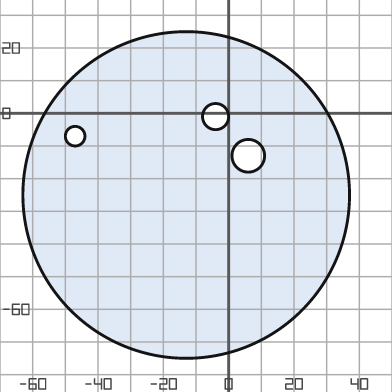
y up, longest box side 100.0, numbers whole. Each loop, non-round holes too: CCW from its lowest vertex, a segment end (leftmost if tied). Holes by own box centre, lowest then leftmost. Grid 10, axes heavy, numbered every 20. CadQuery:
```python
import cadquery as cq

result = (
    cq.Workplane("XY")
    .moveTo(-13.0, -25.0)
    .circle(50.0)
    .moveTo(6.0, -13.0)
    .circle(5.0)
    .moveTo(-47.0, -7.0)
    .circle(3.0)
    .moveTo(-4.0, -1.0)
    .circle(4.0)
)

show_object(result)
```